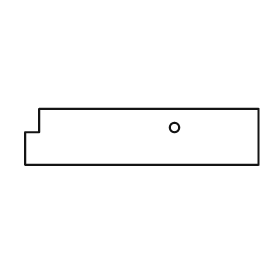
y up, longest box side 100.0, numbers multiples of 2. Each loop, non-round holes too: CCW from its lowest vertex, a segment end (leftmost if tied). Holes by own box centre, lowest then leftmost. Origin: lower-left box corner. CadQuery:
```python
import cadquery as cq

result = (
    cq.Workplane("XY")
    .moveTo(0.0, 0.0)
    .lineTo(100.0, 0.0)
    .lineTo(100.0, 24.0)
    .lineTo(6.0, 24.0)
    .lineTo(6.0, 14.0)
    .lineTo(0.0, 14.0)
    .close()
    .moveTo(64.0, 16.0)
    .circle(2.0)
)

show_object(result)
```